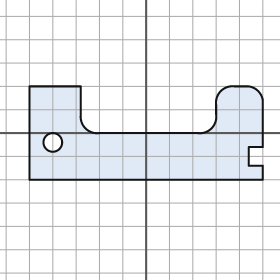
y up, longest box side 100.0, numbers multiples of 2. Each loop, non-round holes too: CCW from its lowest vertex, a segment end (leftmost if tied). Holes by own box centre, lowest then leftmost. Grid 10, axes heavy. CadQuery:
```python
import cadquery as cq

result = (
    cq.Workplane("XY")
    .moveTo(-50.0, -20.0)
    .lineTo(50.0, -20.0)
    .lineTo(50.0, -14.0)
    .lineTo(44.0, -14.0)
    .lineTo(44.0, -6.0)
    .lineTo(50.0, -6.0)
    .lineTo(50.0, 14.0)
    .threePointArc((48.0, 18.0), (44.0, 20.0))
    .lineTo(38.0, 20.0)
    .threePointArc((32.0, 18.0), (30.0, 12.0))
    .lineTo(30.0, 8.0)
    .threePointArc((28.0, 2.0), (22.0, 0.0))
    .lineTo(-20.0, 0.0)
    .threePointArc((-26.0, 2.0), (-28.0, 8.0))
    .lineTo(-28.0, 20.0)
    .lineTo(-50.0, 20.0)
    .close()
    .moveTo(-40.0, -4.0)
    .circle(4.0)
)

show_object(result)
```